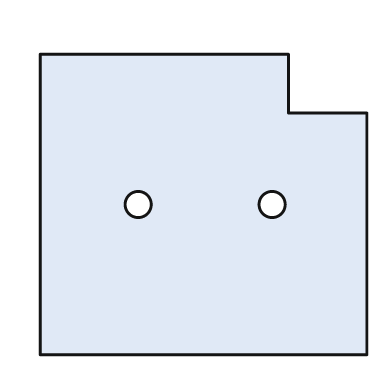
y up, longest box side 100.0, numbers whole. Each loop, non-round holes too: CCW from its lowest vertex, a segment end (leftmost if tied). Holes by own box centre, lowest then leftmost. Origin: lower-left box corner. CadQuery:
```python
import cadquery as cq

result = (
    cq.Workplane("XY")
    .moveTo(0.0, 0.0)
    .lineTo(100.0, 0.0)
    .lineTo(100.0, 74.0)
    .lineTo(76.0, 74.0)
    .lineTo(76.0, 92.0)
    .lineTo(0.0, 92.0)
    .close()
    .moveTo(30.0, 46.0)
    .circle(4.0)
    .moveTo(71.0, 46.0)
    .circle(4.0)
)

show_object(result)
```